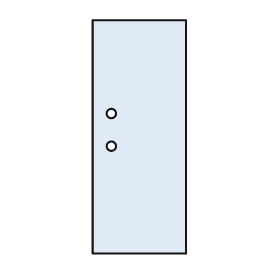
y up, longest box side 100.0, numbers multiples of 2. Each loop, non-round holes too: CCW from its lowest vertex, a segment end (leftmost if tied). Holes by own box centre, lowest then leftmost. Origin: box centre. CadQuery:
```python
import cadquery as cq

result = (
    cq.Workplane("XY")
    .moveTo(-20.0, -50.0)
    .lineTo(20.0, -50.0)
    .lineTo(20.0, 50.0)
    .lineTo(-20.0, 50.0)
    .close()
    .moveTo(-12.0, -4.0)
    .circle(2.0)
    .moveTo(-12.0, 10.0)
    .circle(2.0)
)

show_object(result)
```